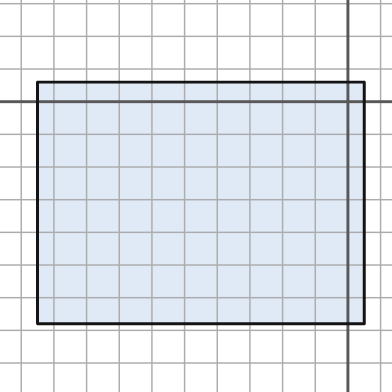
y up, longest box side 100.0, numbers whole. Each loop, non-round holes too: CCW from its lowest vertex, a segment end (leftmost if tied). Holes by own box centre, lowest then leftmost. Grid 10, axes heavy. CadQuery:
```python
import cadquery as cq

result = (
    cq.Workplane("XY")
    .moveTo(-95.0, -68.0)
    .lineTo(5.0, -68.0)
    .lineTo(5.0, 6.0)
    .lineTo(-95.0, 6.0)
    .close()
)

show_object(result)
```